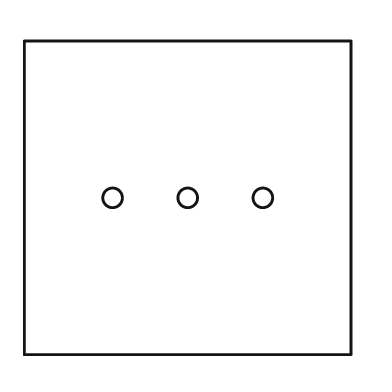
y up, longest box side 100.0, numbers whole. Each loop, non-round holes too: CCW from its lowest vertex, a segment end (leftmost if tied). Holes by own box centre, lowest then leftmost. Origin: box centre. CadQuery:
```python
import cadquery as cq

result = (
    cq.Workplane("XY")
    .moveTo(-50.0, -48.0)
    .lineTo(50.0, -48.0)
    .lineTo(50.0, 48.0)
    .lineTo(-50.0, 48.0)
    .close()
    .moveTo(-23.0, 0.0)
    .circle(3.0)
    .moveTo(0.0, 0.0)
    .circle(3.0)
    .moveTo(23.0, 0.0)
    .circle(3.0)
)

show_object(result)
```